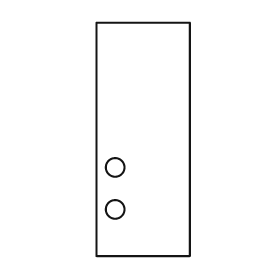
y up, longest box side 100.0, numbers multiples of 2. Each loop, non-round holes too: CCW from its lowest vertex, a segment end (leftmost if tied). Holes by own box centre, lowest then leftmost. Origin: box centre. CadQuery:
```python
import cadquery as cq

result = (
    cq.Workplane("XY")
    .moveTo(-20.0, -50.0)
    .lineTo(20.0, -50.0)
    .lineTo(20.0, 50.0)
    .lineTo(-20.0, 50.0)
    .close()
    .moveTo(-12.0, -30.0)
    .circle(4.0)
    .moveTo(-12.0, -12.0)
    .circle(4.0)
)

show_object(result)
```